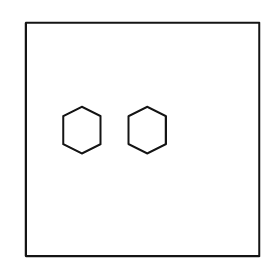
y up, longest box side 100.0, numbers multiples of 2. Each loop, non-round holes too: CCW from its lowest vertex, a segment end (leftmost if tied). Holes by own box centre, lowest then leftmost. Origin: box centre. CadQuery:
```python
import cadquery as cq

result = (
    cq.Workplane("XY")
    .moveTo(-50.0, -50.0)
    .lineTo(50.0, -50.0)
    .lineTo(50.0, 50.0)
    .lineTo(-50.0, 50.0)
    .close()
    .moveTo(-26.0, -6.0)
    .lineTo(-18.0, -2.0)
    .lineTo(-18.0, 10.0)
    .lineTo(-26.0, 14.0)
    .lineTo(-34.0, 10.0)
    .lineTo(-34.0, -2.0)
    .close()
    .moveTo(2.0, -6.0)
    .lineTo(10.0, -2.0)
    .lineTo(10.0, 10.0)
    .lineTo(2.0, 14.0)
    .lineTo(-6.0, 10.0)
    .lineTo(-6.0, -2.0)
    .close()
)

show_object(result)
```